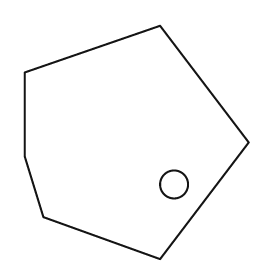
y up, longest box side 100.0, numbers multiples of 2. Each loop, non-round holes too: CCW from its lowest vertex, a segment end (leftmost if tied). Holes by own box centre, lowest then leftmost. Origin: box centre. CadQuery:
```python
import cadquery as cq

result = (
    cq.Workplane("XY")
    .moveTo(10.0, -50.0)
    .lineTo(48.0, 0.0)
    .lineTo(10.0, 50.0)
    .lineTo(-48.0, 30.0)
    .lineTo(-48.0, -6.0)
    .lineTo(-40.0, -32.0)
    .close()
    .moveTo(16.0, -18.0)
    .circle(6.0)
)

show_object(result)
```